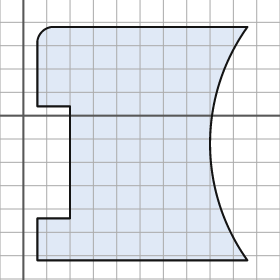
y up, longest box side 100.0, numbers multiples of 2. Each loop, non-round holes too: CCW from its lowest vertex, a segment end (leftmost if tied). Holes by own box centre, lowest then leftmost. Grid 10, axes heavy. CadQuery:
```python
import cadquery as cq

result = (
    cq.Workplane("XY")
    .moveTo(6.0, -62.0)
    .lineTo(96.0, -62.0)
    .threePointArc((80.0, -12.0), (96.0, 38.0))
    .lineTo(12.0, 38.0)
    .threePointArc((8.0, 36.0), (6.0, 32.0))
    .lineTo(6.0, 4.0)
    .lineTo(20.0, 4.0)
    .lineTo(20.0, -44.0)
    .lineTo(6.0, -44.0)
    .close()
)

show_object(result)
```